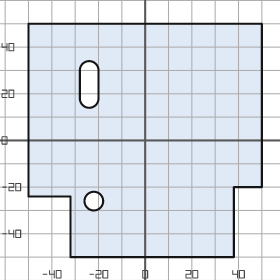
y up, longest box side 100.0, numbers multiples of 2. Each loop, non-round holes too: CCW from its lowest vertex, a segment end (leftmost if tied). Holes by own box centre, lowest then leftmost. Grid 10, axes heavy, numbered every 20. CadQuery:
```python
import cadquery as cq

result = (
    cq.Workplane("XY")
    .moveTo(-32.0, -50.0)
    .lineTo(38.0, -50.0)
    .lineTo(38.0, -20.0)
    .lineTo(50.0, -20.0)
    .lineTo(50.0, 50.0)
    .lineTo(-50.0, 50.0)
    .lineTo(-50.0, -24.0)
    .lineTo(-32.0, -24.0)
    .close()
    .moveTo(-22.0, -26.0)
    .circle(4.0)
    .moveTo(-28.0, 18.0)
    .threePointArc((-24.0, 14.0), (-20.0, 18.0))
    .lineTo(-20.0, 30.0)
    .threePointArc((-24.0, 34.0), (-28.0, 30.0))
    .close()
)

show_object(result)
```